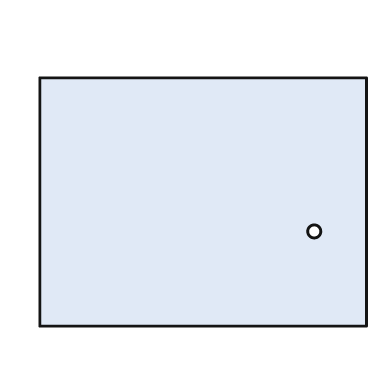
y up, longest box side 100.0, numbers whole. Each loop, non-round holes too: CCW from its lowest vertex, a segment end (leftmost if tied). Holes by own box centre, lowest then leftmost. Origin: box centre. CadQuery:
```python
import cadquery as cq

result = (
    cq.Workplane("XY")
    .moveTo(-50.0, -38.0)
    .lineTo(50.0, -38.0)
    .lineTo(50.0, 38.0)
    .lineTo(-50.0, 38.0)
    .close()
    .moveTo(34.0, -9.0)
    .circle(2.0)
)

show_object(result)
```